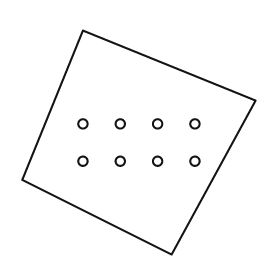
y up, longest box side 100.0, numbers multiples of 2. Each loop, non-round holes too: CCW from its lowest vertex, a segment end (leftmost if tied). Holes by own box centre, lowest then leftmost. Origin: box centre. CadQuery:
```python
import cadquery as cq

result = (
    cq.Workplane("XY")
    .moveTo(14.0, -48.0)
    .lineTo(50.0, 18.0)
    .lineTo(-24.0, 48.0)
    .lineTo(-50.0, -16.0)
    .close()
    .moveTo(-24.0, -8.0)
    .circle(2.0)
    .moveTo(-8.0, -8.0)
    .circle(2.0)
    .moveTo(8.0, -8.0)
    .circle(2.0)
    .moveTo(24.0, -8.0)
    .circle(2.0)
    .moveTo(-24.0, 8.0)
    .circle(2.0)
    .moveTo(-8.0, 8.0)
    .circle(2.0)
    .moveTo(8.0, 8.0)
    .circle(2.0)
    .moveTo(24.0, 8.0)
    .circle(2.0)
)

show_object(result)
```